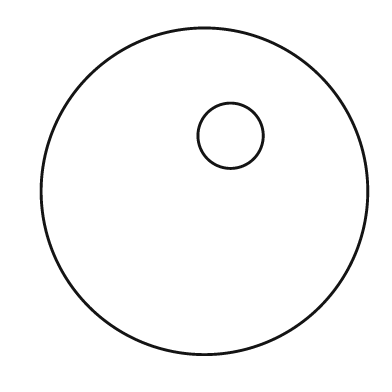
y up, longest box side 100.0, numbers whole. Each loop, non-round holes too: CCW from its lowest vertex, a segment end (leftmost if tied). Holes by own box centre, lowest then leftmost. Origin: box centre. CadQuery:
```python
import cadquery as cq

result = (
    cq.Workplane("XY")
    .moveTo(0.0, 0.0)
    .circle(50.0)
    .moveTo(8.0, 17.0)
    .circle(10.0)
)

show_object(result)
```